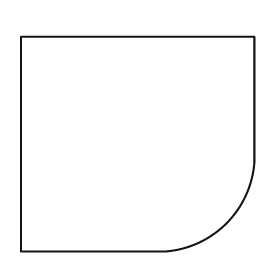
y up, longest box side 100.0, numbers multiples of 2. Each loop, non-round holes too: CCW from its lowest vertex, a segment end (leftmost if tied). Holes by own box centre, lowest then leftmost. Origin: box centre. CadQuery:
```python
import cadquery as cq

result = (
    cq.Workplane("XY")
    .moveTo(-50.0, -46.0)
    .lineTo(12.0, -46.0)
    .threePointArc((38.0, -34.0), (50.0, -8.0))
    .lineTo(50.0, 46.0)
    .lineTo(-50.0, 46.0)
    .close()
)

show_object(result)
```